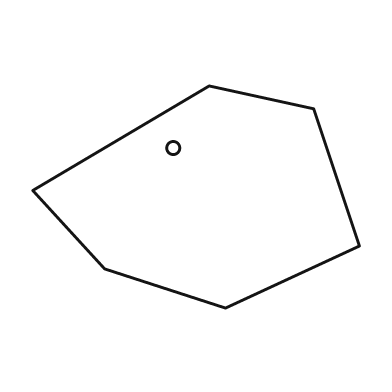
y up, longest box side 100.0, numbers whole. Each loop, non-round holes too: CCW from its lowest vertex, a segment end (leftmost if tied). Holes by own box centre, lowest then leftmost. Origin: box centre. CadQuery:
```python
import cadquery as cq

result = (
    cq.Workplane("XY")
    .moveTo(9.0, -34.0)
    .lineTo(50.0, -15.0)
    .lineTo(36.0, 27.0)
    .lineTo(4.0, 34.0)
    .lineTo(-50.0, 2.0)
    .lineTo(-28.0, -22.0)
    .close()
    .moveTo(-7.0, 15.0)
    .circle(2.0)
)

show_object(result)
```